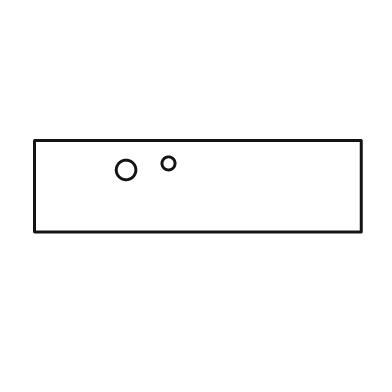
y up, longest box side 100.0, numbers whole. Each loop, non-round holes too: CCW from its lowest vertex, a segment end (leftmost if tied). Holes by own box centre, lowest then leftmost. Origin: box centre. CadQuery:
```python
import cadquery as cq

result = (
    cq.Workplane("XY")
    .moveTo(-50.0, -14.0)
    .lineTo(50.0, -14.0)
    .lineTo(50.0, 14.0)
    .lineTo(-50.0, 14.0)
    .close()
    .moveTo(-22.0, 5.0)
    .circle(3.0)
    .moveTo(-9.0, 7.0)
    .circle(2.0)
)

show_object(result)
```